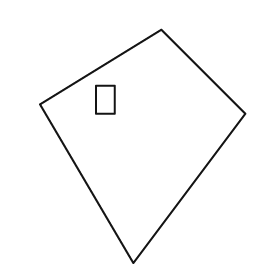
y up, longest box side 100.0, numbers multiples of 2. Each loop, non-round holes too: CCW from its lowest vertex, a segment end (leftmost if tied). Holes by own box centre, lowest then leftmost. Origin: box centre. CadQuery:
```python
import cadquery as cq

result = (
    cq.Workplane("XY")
    .moveTo(-4.0, -50.0)
    .lineTo(44.0, 14.0)
    .lineTo(8.0, 50.0)
    .lineTo(-44.0, 18.0)
    .close()
    .moveTo(-20.0, 14.0)
    .lineTo(-12.0, 14.0)
    .lineTo(-12.0, 26.0)
    .lineTo(-20.0, 26.0)
    .close()
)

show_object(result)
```